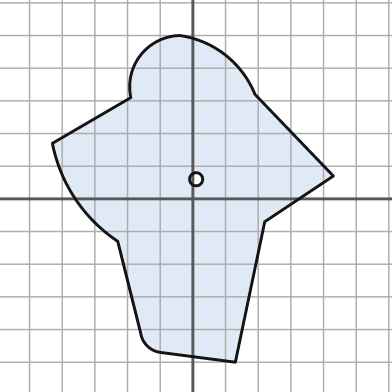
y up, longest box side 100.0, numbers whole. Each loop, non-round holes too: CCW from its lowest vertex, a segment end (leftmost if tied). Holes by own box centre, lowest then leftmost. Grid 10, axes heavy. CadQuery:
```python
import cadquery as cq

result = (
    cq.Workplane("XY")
    .moveTo(13.0, -50.0)
    .lineTo(22.0, -7.0)
    .lineTo(43.0, 7.0)
    .lineTo(19.0, 32.0)
    .threePointArc((10.0, 44.0), (-4.0, 50.0))
    .threePointArc((-16.0, 44.0), (-19.0, 31.0))
    .lineTo(-43.0, 17.0)
    .threePointArc((-36.0, 0.0), (-23.0, -13.0))
    .lineTo(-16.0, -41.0)
    .threePointArc((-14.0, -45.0), (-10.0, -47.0))
    .close()
    .moveTo(1.0, 6.0)
    .circle(2.0)
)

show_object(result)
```